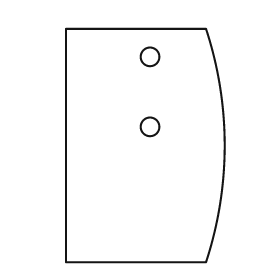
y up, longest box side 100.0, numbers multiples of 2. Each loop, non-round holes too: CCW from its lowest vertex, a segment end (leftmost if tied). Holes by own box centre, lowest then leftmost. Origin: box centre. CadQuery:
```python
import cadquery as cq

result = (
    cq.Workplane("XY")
    .moveTo(-34.0, -50.0)
    .lineTo(26.0, -50.0)
    .threePointArc((34.0, 0.0), (26.0, 50.0))
    .lineTo(-34.0, 50.0)
    .close()
    .moveTo(2.0, 8.0)
    .circle(4.0)
    .moveTo(2.0, 38.0)
    .circle(4.0)
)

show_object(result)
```